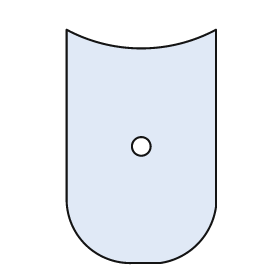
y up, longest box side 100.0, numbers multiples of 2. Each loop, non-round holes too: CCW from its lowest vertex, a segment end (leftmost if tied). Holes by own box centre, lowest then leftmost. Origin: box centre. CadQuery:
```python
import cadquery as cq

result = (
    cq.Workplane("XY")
    .moveTo(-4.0, -50.0)
    .lineTo(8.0, -50.0)
    .threePointArc((24.0, -42.0), (32.0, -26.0))
    .lineTo(32.0, 50.0)
    .threePointArc((0.0, 42.0), (-32.0, 50.0))
    .lineTo(-32.0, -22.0)
    .threePointArc((-24.0, -42.0), (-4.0, -50.0))
    .close()
    .moveTo(0.0, 0.0)
    .circle(4.0)
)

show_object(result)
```